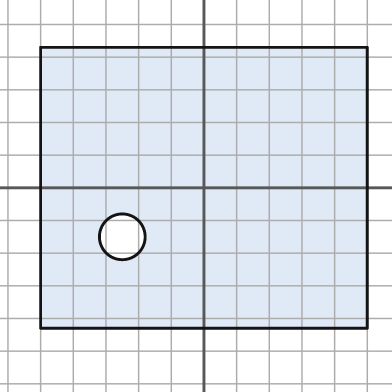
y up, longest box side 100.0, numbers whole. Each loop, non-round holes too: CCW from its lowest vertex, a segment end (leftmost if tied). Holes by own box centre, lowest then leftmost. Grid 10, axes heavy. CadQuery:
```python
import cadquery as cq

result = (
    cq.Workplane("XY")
    .moveTo(-50.0, -43.0)
    .lineTo(50.0, -43.0)
    .lineTo(50.0, 43.0)
    .lineTo(-50.0, 43.0)
    .close()
    .moveTo(-25.0, -15.0)
    .circle(7.0)
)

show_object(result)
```